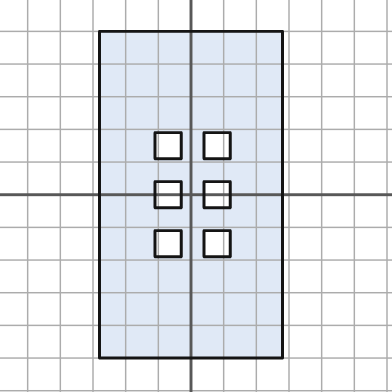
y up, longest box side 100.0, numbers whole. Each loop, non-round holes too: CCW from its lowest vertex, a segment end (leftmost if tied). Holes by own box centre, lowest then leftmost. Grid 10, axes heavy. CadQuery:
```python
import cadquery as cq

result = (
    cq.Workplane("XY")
    .moveTo(-28.0, -50.0)
    .lineTo(28.0, -50.0)
    .lineTo(28.0, 50.0)
    .lineTo(-28.0, 50.0)
    .close()
    .moveTo(-11.0, -19.0)
    .lineTo(-3.0, -19.0)
    .lineTo(-3.0, -11.0)
    .lineTo(-11.0, -11.0)
    .close()
    .moveTo(4.0, -19.0)
    .lineTo(12.0, -19.0)
    .lineTo(12.0, -11.0)
    .lineTo(4.0, -11.0)
    .close()
    .moveTo(-11.0, -4.0)
    .lineTo(-3.0, -4.0)
    .lineTo(-3.0, 4.0)
    .lineTo(-11.0, 4.0)
    .close()
    .moveTo(4.0, -4.0)
    .lineTo(12.0, -4.0)
    .lineTo(12.0, 4.0)
    .lineTo(4.0, 4.0)
    .close()
    .moveTo(-11.0, 11.0)
    .lineTo(-3.0, 11.0)
    .lineTo(-3.0, 19.0)
    .lineTo(-11.0, 19.0)
    .close()
    .moveTo(4.0, 11.0)
    .lineTo(12.0, 11.0)
    .lineTo(12.0, 19.0)
    .lineTo(4.0, 19.0)
    .close()
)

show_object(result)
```